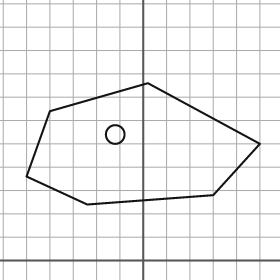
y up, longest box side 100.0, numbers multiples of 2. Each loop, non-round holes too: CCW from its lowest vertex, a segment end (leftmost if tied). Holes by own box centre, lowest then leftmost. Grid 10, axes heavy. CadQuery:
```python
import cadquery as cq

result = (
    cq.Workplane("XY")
    .moveTo(-24.0, 24.0)
    .lineTo(30.0, 28.0)
    .lineTo(50.0, 50.0)
    .lineTo(2.0, 76.0)
    .lineTo(-40.0, 64.0)
    .lineTo(-50.0, 36.0)
    .close()
    .moveTo(-12.0, 54.0)
    .circle(4.0)
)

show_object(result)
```